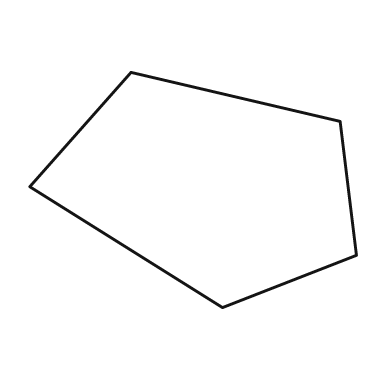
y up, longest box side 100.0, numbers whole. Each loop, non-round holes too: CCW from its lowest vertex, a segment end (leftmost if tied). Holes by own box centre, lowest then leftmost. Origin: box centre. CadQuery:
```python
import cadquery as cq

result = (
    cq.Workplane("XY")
    .moveTo(9.0, -36.0)
    .lineTo(50.0, -20.0)
    .lineTo(45.0, 21.0)
    .lineTo(-19.0, 36.0)
    .lineTo(-50.0, 1.0)
    .close()
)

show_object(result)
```